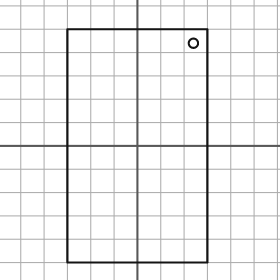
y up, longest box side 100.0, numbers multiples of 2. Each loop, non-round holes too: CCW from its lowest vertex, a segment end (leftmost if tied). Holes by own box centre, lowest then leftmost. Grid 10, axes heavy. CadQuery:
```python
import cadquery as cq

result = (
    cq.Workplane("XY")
    .moveTo(-30.0, -50.0)
    .lineTo(30.0, -50.0)
    .lineTo(30.0, 50.0)
    .lineTo(-30.0, 50.0)
    .close()
    .moveTo(24.0, 44.0)
    .circle(2.0)
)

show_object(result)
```